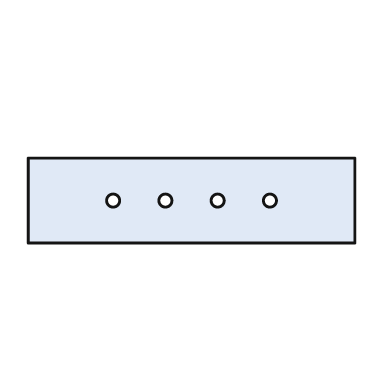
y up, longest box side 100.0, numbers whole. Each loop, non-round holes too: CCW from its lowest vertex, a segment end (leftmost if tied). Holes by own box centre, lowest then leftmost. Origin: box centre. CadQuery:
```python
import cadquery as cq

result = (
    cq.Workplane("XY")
    .moveTo(-50.0, -13.0)
    .lineTo(50.0, -13.0)
    .lineTo(50.0, 13.0)
    .lineTo(-50.0, 13.0)
    .close()
    .moveTo(-24.0, 0.0)
    .circle(2.0)
    .moveTo(-8.0, 0.0)
    .circle(2.0)
    .moveTo(8.0, 0.0)
    .circle(2.0)
    .moveTo(24.0, 0.0)
    .circle(2.0)
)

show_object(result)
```